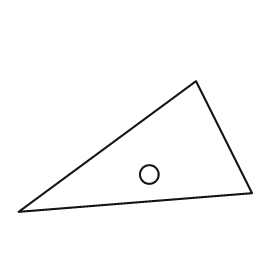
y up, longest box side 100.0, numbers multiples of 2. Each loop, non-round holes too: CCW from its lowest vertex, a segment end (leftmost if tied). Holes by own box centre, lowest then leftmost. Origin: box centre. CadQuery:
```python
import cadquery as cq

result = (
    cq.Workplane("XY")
    .moveTo(-50.0, -28.0)
    .lineTo(50.0, -20.0)
    .lineTo(26.0, 28.0)
    .close()
    .moveTo(6.0, -12.0)
    .circle(4.0)
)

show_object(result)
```